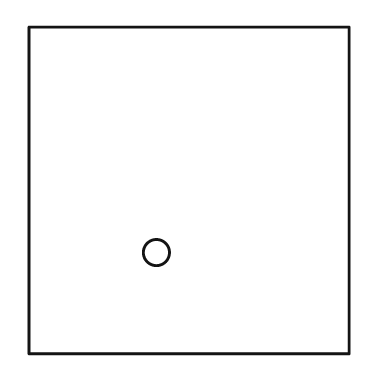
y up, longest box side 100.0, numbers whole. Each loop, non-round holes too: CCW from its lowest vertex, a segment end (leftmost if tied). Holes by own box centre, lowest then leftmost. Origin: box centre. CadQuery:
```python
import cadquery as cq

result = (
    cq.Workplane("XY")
    .moveTo(-49.0, -50.0)
    .lineTo(49.0, -50.0)
    .lineTo(49.0, 50.0)
    .lineTo(-49.0, 50.0)
    .close()
    .moveTo(-10.0, -19.0)
    .circle(4.0)
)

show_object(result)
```